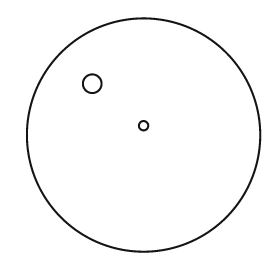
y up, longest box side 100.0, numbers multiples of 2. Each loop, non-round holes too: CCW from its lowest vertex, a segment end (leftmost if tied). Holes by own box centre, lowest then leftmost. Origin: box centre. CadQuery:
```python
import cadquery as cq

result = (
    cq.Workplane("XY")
    .moveTo(0.0, 0.0)
    .circle(50.0)
    .moveTo(0.0, 4.0)
    .circle(2.0)
    .moveTo(-22.0, 22.0)
    .circle(4.0)
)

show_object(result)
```